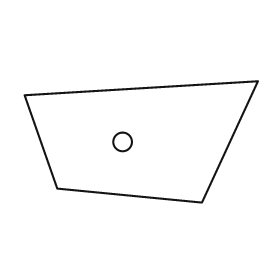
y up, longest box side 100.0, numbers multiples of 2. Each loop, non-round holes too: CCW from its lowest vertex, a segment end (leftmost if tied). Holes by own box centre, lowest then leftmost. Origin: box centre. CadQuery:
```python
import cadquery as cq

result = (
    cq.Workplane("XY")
    .moveTo(26.0, -26.0)
    .lineTo(50.0, 26.0)
    .lineTo(-50.0, 20.0)
    .lineTo(-36.0, -20.0)
    .close()
    .moveTo(-8.0, 0.0)
    .circle(4.0)
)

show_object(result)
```